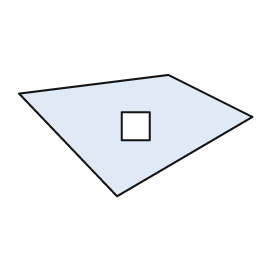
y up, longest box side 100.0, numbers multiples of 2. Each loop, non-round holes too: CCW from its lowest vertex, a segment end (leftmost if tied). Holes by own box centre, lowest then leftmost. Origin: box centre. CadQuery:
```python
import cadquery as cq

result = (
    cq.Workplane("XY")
    .moveTo(-8.0, -26.0)
    .lineTo(50.0, 8.0)
    .lineTo(14.0, 26.0)
    .lineTo(-50.0, 18.0)
    .close()
    .moveTo(-6.0, -2.0)
    .lineTo(6.0, -2.0)
    .lineTo(6.0, 10.0)
    .lineTo(-6.0, 10.0)
    .close()
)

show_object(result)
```